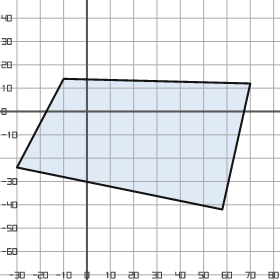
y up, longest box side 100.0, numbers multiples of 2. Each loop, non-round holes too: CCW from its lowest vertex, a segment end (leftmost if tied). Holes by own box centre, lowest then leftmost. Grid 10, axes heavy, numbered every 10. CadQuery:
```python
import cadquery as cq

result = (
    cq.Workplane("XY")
    .moveTo(58.0, -42.0)
    .lineTo(70.0, 12.0)
    .lineTo(-10.0, 14.0)
    .lineTo(-30.0, -24.0)
    .close()
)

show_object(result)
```